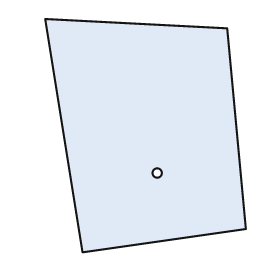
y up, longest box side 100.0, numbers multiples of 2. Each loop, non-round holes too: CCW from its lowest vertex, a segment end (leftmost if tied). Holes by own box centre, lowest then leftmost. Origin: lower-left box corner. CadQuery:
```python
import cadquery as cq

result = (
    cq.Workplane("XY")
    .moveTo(16.0, 0.0)
    .lineTo(86.0, 10.0)
    .lineTo(78.0, 96.0)
    .lineTo(0.0, 100.0)
    .close()
    .moveTo(48.0, 34.0)
    .circle(2.0)
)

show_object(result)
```